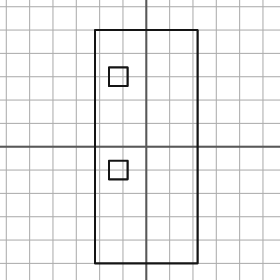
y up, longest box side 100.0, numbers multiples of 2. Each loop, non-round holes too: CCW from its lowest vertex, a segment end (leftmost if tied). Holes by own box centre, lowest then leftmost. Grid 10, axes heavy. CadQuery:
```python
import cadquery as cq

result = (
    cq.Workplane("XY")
    .moveTo(-22.0, -50.0)
    .lineTo(22.0, -50.0)
    .lineTo(22.0, 50.0)
    .lineTo(-22.0, 50.0)
    .close()
    .moveTo(-16.0, -14.0)
    .lineTo(-8.0, -14.0)
    .lineTo(-8.0, -6.0)
    .lineTo(-16.0, -6.0)
    .close()
    .moveTo(-16.0, 26.0)
    .lineTo(-8.0, 26.0)
    .lineTo(-8.0, 34.0)
    .lineTo(-16.0, 34.0)
    .close()
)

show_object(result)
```